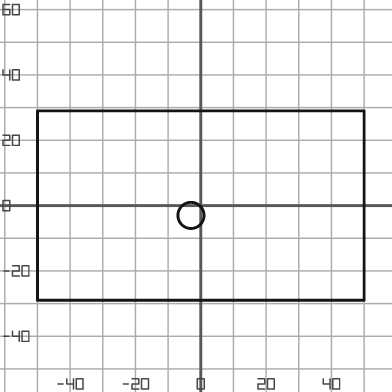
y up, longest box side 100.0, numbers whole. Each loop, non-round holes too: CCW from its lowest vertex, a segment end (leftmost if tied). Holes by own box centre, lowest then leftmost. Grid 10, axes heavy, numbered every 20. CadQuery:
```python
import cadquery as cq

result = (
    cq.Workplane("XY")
    .moveTo(-50.0, -29.0)
    .lineTo(50.0, -29.0)
    .lineTo(50.0, 29.0)
    .lineTo(-50.0, 29.0)
    .close()
    .moveTo(-3.0, -3.0)
    .circle(4.0)
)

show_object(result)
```